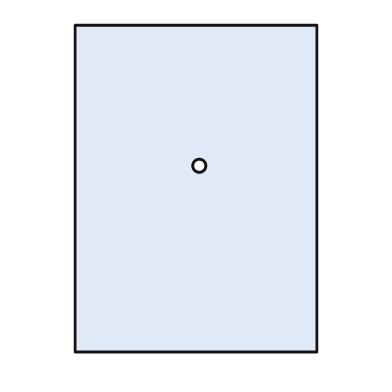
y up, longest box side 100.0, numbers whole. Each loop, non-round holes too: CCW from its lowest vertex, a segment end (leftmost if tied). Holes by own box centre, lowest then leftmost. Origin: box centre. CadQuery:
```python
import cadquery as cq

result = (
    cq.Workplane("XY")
    .moveTo(-37.0, -50.0)
    .lineTo(37.0, -50.0)
    .lineTo(37.0, 50.0)
    .lineTo(-37.0, 50.0)
    .close()
    .moveTo(1.0, 7.0)
    .circle(2.0)
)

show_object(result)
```